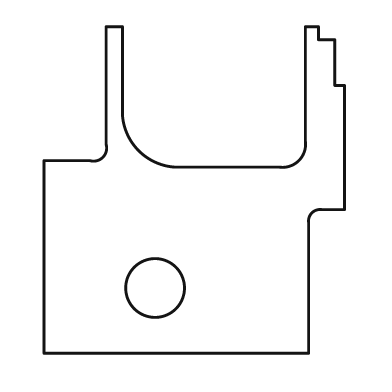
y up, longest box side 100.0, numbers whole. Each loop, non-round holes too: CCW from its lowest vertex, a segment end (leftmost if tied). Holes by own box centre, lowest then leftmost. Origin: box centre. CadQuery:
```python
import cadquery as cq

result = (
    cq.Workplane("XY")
    .moveTo(-46.0, -50.0)
    .lineTo(35.0, -50.0)
    .lineTo(35.0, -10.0)
    .threePointArc((36.0, -7.0), (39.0, -6.0))
    .lineTo(46.0, -6.0)
    .lineTo(46.0, 32.0)
    .lineTo(43.0, 32.0)
    .lineTo(43.0, 46.0)
    .lineTo(38.0, 46.0)
    .lineTo(38.0, 50.0)
    .lineTo(34.0, 50.0)
    .lineTo(34.0, 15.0)
    .threePointArc((32.0, 9.0), (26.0, 7.0))
    .lineTo(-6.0, 7.0)
    .threePointArc((-17.0, 12.0), (-22.0, 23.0))
    .lineTo(-22.0, 50.0)
    .lineTo(-27.0, 50.0)
    .lineTo(-27.0, 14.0)
    .threePointArc((-28.0, 10.0), (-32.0, 9.0))
    .lineTo(-46.0, 9.0)
    .close()
    .moveTo(-12.0, -30.0)
    .circle(9.0)
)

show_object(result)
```